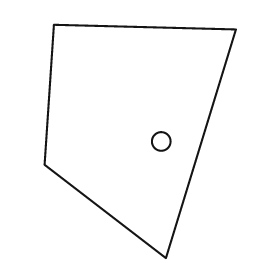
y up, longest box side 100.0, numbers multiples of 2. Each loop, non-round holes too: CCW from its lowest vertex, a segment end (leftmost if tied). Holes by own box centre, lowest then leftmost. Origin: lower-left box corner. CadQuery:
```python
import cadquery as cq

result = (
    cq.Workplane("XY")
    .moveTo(52.0, 0.0)
    .lineTo(82.0, 98.0)
    .lineTo(4.0, 100.0)
    .lineTo(0.0, 40.0)
    .close()
    .moveTo(50.0, 50.0)
    .circle(4.0)
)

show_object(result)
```